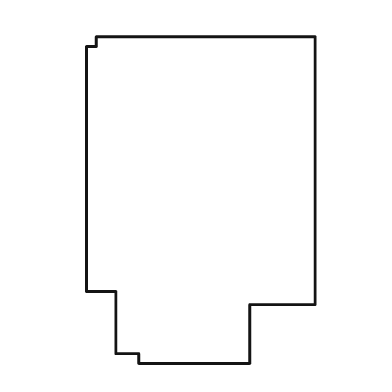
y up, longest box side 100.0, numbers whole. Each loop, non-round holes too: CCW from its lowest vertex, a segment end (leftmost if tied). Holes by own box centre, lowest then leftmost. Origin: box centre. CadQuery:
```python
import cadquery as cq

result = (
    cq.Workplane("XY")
    .moveTo(-19.0, -50.0)
    .lineTo(15.0, -50.0)
    .lineTo(15.0, -32.0)
    .lineTo(35.0, -32.0)
    .lineTo(35.0, 50.0)
    .lineTo(-32.0, 50.0)
    .lineTo(-32.0, 47.0)
    .lineTo(-35.0, 47.0)
    .lineTo(-35.0, -28.0)
    .lineTo(-26.0, -28.0)
    .lineTo(-26.0, -47.0)
    .lineTo(-19.0, -47.0)
    .close()
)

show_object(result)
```